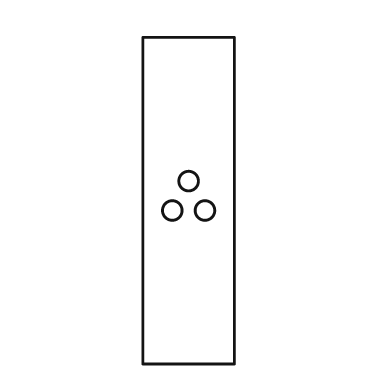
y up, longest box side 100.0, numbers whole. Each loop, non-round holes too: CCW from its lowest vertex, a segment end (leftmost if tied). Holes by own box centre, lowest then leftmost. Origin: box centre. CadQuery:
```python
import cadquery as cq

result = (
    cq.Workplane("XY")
    .moveTo(-14.0, -50.0)
    .lineTo(14.0, -50.0)
    .lineTo(14.0, 50.0)
    .lineTo(-14.0, 50.0)
    .close()
    .moveTo(-5.0, -3.0)
    .circle(3.0)
    .moveTo(5.0, -3.0)
    .circle(3.0)
    .moveTo(0.0, 6.0)
    .circle(3.0)
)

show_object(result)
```